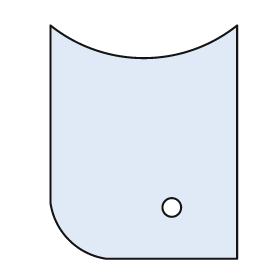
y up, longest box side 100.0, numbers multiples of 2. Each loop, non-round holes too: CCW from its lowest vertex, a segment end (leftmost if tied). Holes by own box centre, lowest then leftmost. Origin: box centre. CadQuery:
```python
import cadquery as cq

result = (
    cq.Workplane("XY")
    .moveTo(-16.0, -50.0)
    .lineTo(40.0, -50.0)
    .lineTo(40.0, 50.0)
    .threePointArc((0.0, 36.0), (-40.0, 50.0))
    .lineTo(-40.0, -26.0)
    .threePointArc((-32.0, -42.0), (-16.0, -50.0))
    .close()
    .moveTo(12.0, -28.0)
    .circle(4.0)
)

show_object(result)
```